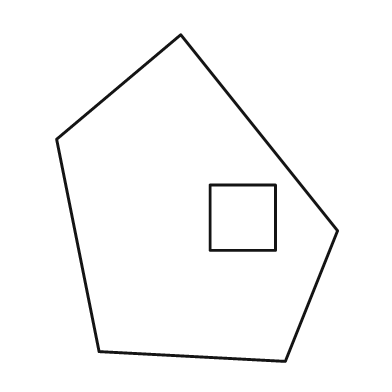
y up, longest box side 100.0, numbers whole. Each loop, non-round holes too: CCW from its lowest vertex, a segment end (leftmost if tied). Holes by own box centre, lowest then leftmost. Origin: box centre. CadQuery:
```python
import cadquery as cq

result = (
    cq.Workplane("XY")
    .moveTo(27.0, -50.0)
    .lineTo(43.0, -10.0)
    .lineTo(-5.0, 50.0)
    .lineTo(-43.0, 18.0)
    .lineTo(-30.0, -47.0)
    .close()
    .moveTo(4.0, -16.0)
    .lineTo(24.0, -16.0)
    .lineTo(24.0, 4.0)
    .lineTo(4.0, 4.0)
    .close()
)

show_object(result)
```